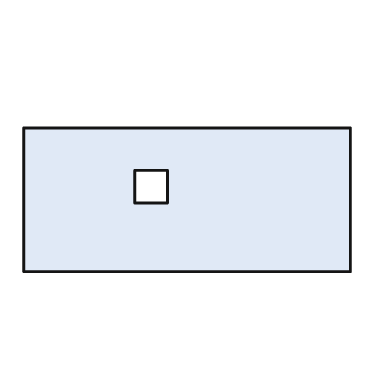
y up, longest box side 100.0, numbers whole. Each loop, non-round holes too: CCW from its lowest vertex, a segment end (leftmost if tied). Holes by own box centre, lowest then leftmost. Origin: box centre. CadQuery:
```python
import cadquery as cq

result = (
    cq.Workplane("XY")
    .moveTo(-50.0, -22.0)
    .lineTo(50.0, -22.0)
    .lineTo(50.0, 22.0)
    .lineTo(-50.0, 22.0)
    .close()
    .moveTo(-16.0, -1.0)
    .lineTo(-6.0, -1.0)
    .lineTo(-6.0, 9.0)
    .lineTo(-16.0, 9.0)
    .close()
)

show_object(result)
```